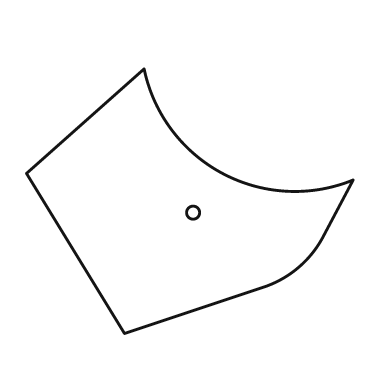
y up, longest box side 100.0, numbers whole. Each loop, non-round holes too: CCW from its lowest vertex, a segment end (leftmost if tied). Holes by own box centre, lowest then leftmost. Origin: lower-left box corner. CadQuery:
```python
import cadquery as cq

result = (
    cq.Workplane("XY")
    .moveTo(30.0, 0.0)
    .lineTo(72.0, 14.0)
    .threePointArc((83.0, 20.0), (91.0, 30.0))
    .lineTo(100.0, 47.0)
    .threePointArc((60.0, 49.0), (36.0, 81.0))
    .lineTo(0.0, 49.0)
    .close()
    .moveTo(51.0, 37.0)
    .circle(2.0)
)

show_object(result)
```